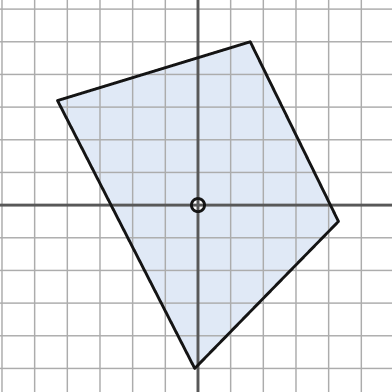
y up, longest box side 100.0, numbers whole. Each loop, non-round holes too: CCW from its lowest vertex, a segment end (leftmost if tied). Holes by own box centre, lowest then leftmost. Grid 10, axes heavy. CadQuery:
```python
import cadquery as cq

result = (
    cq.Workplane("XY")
    .moveTo(-1.0, -50.0)
    .lineTo(43.0, -5.0)
    .lineTo(16.0, 50.0)
    .lineTo(-43.0, 32.0)
    .close()
    .moveTo(0.0, 0.0)
    .circle(2.0)
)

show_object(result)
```